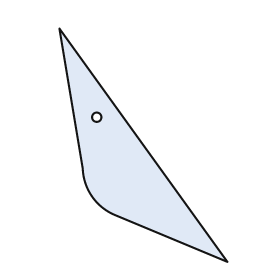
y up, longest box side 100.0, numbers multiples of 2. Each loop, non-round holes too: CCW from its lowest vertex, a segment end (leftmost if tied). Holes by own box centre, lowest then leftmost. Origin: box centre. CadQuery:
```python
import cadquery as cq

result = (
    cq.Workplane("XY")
    .moveTo(36.0, -50.0)
    .lineTo(-36.0, 50.0)
    .lineTo(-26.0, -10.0)
    .threePointArc((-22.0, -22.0), (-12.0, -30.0))
    .close()
    .moveTo(-20.0, 12.0)
    .circle(2.0)
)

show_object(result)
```